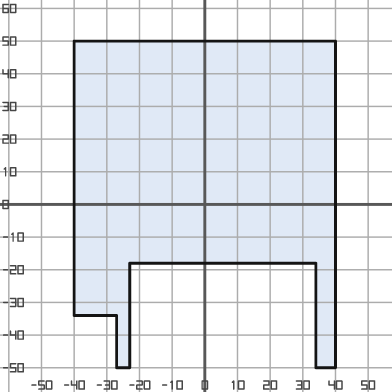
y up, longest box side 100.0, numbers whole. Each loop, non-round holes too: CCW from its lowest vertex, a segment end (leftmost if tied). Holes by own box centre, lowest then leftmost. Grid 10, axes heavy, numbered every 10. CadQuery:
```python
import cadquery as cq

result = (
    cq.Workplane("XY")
    .moveTo(-27.0, -50.0)
    .lineTo(-23.0, -50.0)
    .lineTo(-23.0, -18.0)
    .lineTo(34.0, -18.0)
    .lineTo(34.0, -50.0)
    .lineTo(40.0, -50.0)
    .lineTo(40.0, 50.0)
    .lineTo(-40.0, 50.0)
    .lineTo(-40.0, -34.0)
    .lineTo(-27.0, -34.0)
    .close()
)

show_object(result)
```